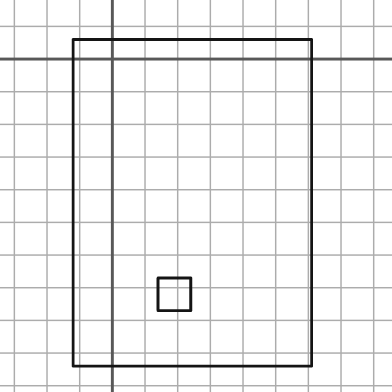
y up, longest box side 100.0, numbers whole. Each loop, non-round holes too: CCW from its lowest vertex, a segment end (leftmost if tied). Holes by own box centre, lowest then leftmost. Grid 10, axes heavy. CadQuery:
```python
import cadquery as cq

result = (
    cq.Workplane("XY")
    .moveTo(-12.0, -94.0)
    .lineTo(61.0, -94.0)
    .lineTo(61.0, 6.0)
    .lineTo(-12.0, 6.0)
    .close()
    .moveTo(14.0, -77.0)
    .lineTo(24.0, -77.0)
    .lineTo(24.0, -67.0)
    .lineTo(14.0, -67.0)
    .close()
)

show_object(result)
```